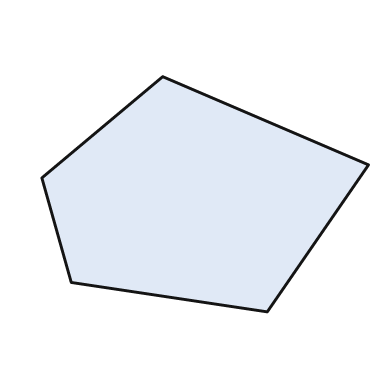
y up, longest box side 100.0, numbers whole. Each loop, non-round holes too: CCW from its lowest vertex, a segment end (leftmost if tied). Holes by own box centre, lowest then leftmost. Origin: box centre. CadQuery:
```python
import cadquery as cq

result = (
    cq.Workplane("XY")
    .moveTo(19.0, -36.0)
    .lineTo(50.0, 9.0)
    .lineTo(-13.0, 36.0)
    .lineTo(-50.0, 5.0)
    .lineTo(-41.0, -27.0)
    .close()
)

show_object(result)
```